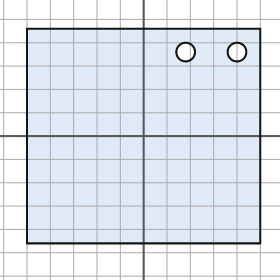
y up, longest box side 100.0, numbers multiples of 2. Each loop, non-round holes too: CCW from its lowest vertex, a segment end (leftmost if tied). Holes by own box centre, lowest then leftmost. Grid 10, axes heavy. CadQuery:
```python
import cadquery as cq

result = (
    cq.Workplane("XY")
    .moveTo(-50.0, -46.0)
    .lineTo(50.0, -46.0)
    .lineTo(50.0, 46.0)
    .lineTo(-50.0, 46.0)
    .close()
    .moveTo(18.0, 36.0)
    .circle(4.0)
    .moveTo(40.0, 36.0)
    .circle(4.0)
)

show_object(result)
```